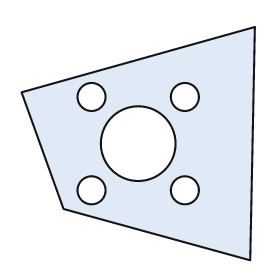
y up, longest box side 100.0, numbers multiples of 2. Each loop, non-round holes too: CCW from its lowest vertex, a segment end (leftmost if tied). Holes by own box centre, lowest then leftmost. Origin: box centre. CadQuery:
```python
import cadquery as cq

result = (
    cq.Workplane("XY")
    .moveTo(48.0, -50.0)
    .lineTo(50.0, 50.0)
    .lineTo(-50.0, 22.0)
    .lineTo(-32.0, -28.0)
    .close()
    .moveTo(-20.0, -20.0)
    .circle(6.0)
    .moveTo(20.0, -20.0)
    .circle(6.0)
    .moveTo(0.0, 0.0)
    .circle(16.0)
    .moveTo(-20.0, 20.0)
    .circle(6.0)
    .moveTo(20.0, 20.0)
    .circle(6.0)
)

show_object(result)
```